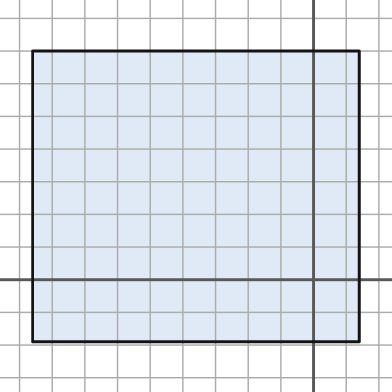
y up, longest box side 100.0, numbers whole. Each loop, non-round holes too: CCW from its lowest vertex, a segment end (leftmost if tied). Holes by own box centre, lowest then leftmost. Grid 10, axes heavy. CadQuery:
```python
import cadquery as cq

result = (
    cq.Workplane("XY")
    .moveTo(-86.0, -19.0)
    .lineTo(14.0, -19.0)
    .lineTo(14.0, 70.0)
    .lineTo(-86.0, 70.0)
    .close()
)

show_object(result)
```